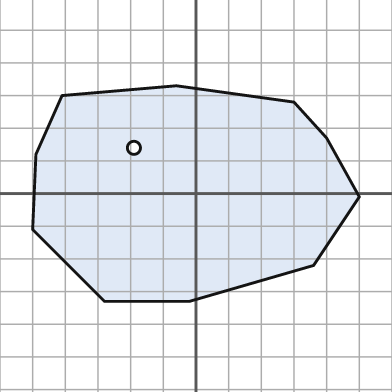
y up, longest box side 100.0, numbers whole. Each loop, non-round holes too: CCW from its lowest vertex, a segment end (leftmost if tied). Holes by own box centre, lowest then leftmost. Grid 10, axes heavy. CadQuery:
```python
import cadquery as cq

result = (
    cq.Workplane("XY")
    .moveTo(-28.0, -33.0)
    .lineTo(-2.0, -33.0)
    .lineTo(36.0, -22.0)
    .lineTo(50.0, -1.0)
    .lineTo(40.0, 17.0)
    .lineTo(30.0, 28.0)
    .lineTo(-6.0, 33.0)
    .lineTo(-41.0, 30.0)
    .lineTo(-49.0, 12.0)
    .lineTo(-50.0, -11.0)
    .close()
    .moveTo(-19.0, 14.0)
    .circle(2.0)
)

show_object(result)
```